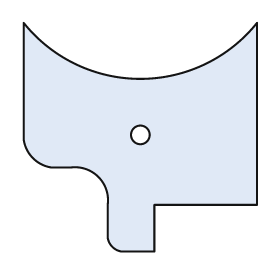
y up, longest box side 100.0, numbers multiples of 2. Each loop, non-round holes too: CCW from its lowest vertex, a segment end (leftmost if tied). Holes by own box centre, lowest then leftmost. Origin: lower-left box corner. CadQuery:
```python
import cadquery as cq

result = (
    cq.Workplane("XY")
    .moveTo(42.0, 0.0)
    .lineTo(56.0, 0.0)
    .lineTo(56.0, 20.0)
    .lineTo(100.0, 20.0)
    .lineTo(100.0, 98.0)
    .threePointArc((50.0, 74.0), (0.0, 98.0))
    .lineTo(0.0, 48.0)
    .threePointArc((4.0, 40.0), (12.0, 36.0))
    .lineTo(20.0, 36.0)
    .threePointArc((32.0, 32.0), (36.0, 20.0))
    .lineTo(36.0, 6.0)
    .threePointArc((38.0, 2.0), (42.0, 0.0))
    .close()
    .moveTo(50.0, 50.0)
    .circle(4.0)
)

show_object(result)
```